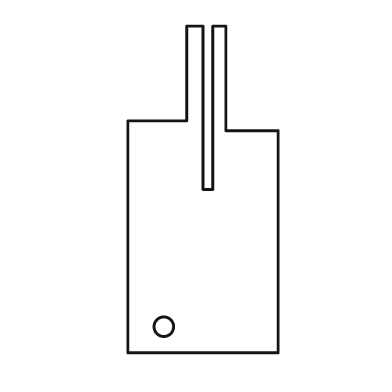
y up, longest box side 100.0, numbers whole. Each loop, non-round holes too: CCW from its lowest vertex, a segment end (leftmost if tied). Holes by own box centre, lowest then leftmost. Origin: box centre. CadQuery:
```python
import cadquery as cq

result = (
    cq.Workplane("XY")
    .moveTo(-23.0, -50.0)
    .lineTo(23.0, -50.0)
    .lineTo(23.0, 18.0)
    .lineTo(7.0, 18.0)
    .lineTo(7.0, 50.0)
    .lineTo(3.0, 50.0)
    .lineTo(3.0, 0.0)
    .lineTo(0.0, 0.0)
    .lineTo(0.0, 50.0)
    .lineTo(-5.0, 50.0)
    .lineTo(-5.0, 21.0)
    .lineTo(-23.0, 21.0)
    .close()
    .moveTo(-12.0, -42.0)
    .circle(3.0)
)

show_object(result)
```